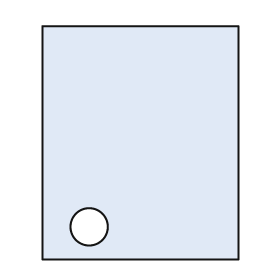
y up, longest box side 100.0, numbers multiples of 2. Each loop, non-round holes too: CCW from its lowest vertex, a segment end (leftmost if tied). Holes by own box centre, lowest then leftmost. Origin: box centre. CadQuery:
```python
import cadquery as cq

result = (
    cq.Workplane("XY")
    .moveTo(-42.0, -50.0)
    .lineTo(42.0, -50.0)
    .lineTo(42.0, 50.0)
    .lineTo(-42.0, 50.0)
    .close()
    .moveTo(-22.0, -36.0)
    .circle(8.0)
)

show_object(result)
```